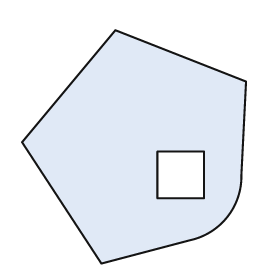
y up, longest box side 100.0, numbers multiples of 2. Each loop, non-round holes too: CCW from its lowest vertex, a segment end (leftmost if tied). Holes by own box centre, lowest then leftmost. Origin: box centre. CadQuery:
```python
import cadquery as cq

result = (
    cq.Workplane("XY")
    .moveTo(-14.0, -50.0)
    .lineTo(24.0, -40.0)
    .threePointArc((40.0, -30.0), (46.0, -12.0))
    .lineTo(48.0, 28.0)
    .lineTo(-8.0, 50.0)
    .lineTo(-48.0, 2.0)
    .close()
    .moveTo(10.0, -22.0)
    .lineTo(30.0, -22.0)
    .lineTo(30.0, -2.0)
    .lineTo(10.0, -2.0)
    .close()
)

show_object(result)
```